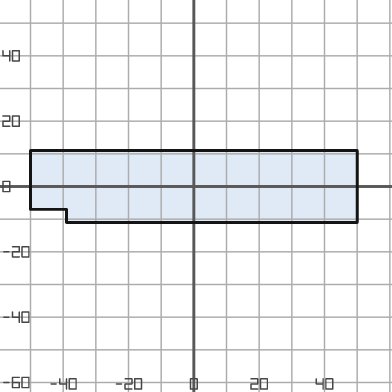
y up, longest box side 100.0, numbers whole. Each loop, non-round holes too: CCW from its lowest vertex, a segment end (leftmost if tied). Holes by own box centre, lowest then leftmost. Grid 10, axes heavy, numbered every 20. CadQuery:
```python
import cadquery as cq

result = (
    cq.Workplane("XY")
    .moveTo(-39.0, -11.0)
    .lineTo(50.0, -11.0)
    .lineTo(50.0, 11.0)
    .lineTo(-50.0, 11.0)
    .lineTo(-50.0, -7.0)
    .lineTo(-39.0, -7.0)
    .close()
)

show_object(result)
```